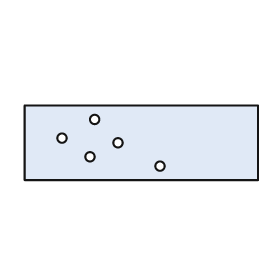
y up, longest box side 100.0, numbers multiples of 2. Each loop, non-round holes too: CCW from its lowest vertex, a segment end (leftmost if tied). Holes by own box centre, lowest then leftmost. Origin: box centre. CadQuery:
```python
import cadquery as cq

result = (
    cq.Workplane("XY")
    .moveTo(-50.0, -16.0)
    .lineTo(50.0, -16.0)
    .lineTo(50.0, 16.0)
    .lineTo(-50.0, 16.0)
    .close()
    .moveTo(8.0, -10.0)
    .circle(2.0)
    .moveTo(-22.0, -6.0)
    .circle(2.0)
    .moveTo(-10.0, 0.0)
    .circle(2.0)
    .moveTo(-34.0, 2.0)
    .circle(2.0)
    .moveTo(-20.0, 10.0)
    .circle(2.0)
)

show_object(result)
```